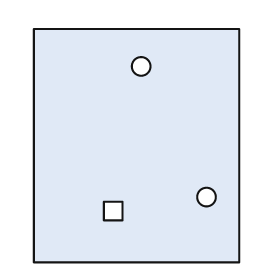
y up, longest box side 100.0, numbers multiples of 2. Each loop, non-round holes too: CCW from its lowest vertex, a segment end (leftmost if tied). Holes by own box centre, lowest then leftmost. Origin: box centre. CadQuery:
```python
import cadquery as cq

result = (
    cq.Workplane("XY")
    .moveTo(-44.0, -50.0)
    .lineTo(44.0, -50.0)
    .lineTo(44.0, 50.0)
    .lineTo(-44.0, 50.0)
    .close()
    .moveTo(-14.0, -32.0)
    .lineTo(-6.0, -32.0)
    .lineTo(-6.0, -24.0)
    .lineTo(-14.0, -24.0)
    .close()
    .moveTo(30.0, -22.0)
    .circle(4.0)
    .moveTo(2.0, 34.0)
    .circle(4.0)
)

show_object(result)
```